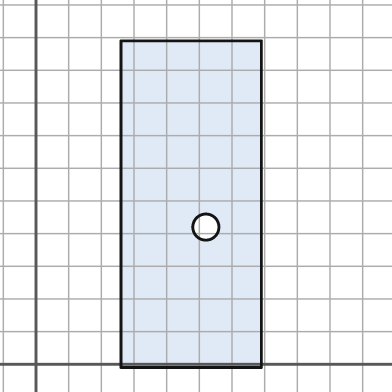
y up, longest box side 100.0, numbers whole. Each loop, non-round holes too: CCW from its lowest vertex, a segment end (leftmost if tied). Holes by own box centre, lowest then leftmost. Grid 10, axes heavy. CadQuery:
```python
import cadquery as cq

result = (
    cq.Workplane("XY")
    .moveTo(26.0, -1.0)
    .lineTo(69.0, -1.0)
    .lineTo(69.0, 99.0)
    .lineTo(26.0, 99.0)
    .close()
    .moveTo(52.0, 42.0)
    .circle(4.0)
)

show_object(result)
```